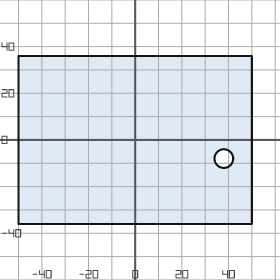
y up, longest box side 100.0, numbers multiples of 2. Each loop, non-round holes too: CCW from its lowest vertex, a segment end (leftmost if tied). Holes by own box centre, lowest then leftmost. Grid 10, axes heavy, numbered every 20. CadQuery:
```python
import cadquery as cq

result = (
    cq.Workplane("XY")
    .moveTo(-50.0, -36.0)
    .lineTo(50.0, -36.0)
    .lineTo(50.0, 36.0)
    .lineTo(-50.0, 36.0)
    .close()
    .moveTo(38.0, -8.0)
    .circle(4.0)
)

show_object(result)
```